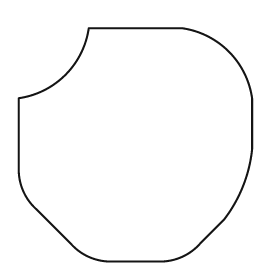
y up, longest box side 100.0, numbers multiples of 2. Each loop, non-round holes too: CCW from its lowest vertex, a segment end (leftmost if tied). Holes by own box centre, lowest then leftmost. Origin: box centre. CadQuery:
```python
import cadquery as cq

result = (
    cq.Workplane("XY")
    .moveTo(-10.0, -50.0)
    .lineTo(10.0, -50.0)
    .threePointArc((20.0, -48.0), (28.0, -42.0))
    .lineTo(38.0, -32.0)
    .threePointArc((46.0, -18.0), (50.0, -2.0))
    .lineTo(50.0, 20.0)
    .threePointArc((40.0, 40.0), (20.0, 50.0))
    .lineTo(-20.0, 50.0)
    .threePointArc((-30.0, 30.0), (-50.0, 20.0))
    .lineTo(-50.0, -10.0)
    .threePointArc((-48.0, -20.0), (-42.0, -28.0))
    .lineTo(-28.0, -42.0)
    .threePointArc((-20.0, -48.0), (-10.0, -50.0))
    .close()
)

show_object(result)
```